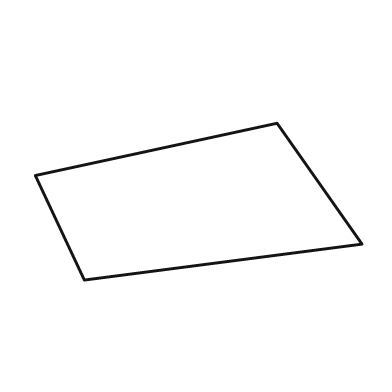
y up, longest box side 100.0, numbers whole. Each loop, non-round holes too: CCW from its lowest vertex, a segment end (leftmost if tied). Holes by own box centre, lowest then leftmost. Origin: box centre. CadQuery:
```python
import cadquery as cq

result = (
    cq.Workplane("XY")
    .moveTo(-35.0, -24.0)
    .lineTo(50.0, -13.0)
    .lineTo(24.0, 24.0)
    .lineTo(-50.0, 8.0)
    .close()
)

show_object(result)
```